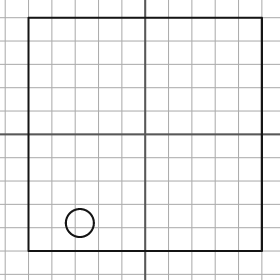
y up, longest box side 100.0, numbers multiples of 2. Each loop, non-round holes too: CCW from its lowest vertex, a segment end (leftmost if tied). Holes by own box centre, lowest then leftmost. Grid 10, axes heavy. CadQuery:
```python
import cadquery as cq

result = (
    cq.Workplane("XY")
    .moveTo(-50.0, -50.0)
    .lineTo(50.0, -50.0)
    .lineTo(50.0, 50.0)
    .lineTo(-50.0, 50.0)
    .close()
    .moveTo(-28.0, -38.0)
    .circle(6.0)
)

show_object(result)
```